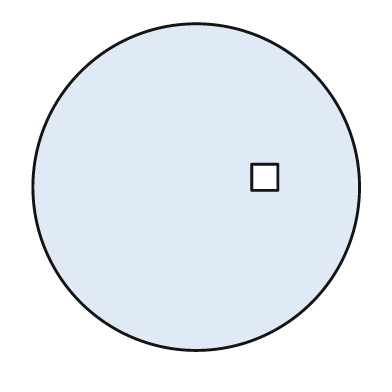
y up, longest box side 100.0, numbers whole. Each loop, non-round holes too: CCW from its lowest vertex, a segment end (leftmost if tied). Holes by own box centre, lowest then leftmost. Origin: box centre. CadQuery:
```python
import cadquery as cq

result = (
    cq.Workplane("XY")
    .moveTo(0.0, 0.0)
    .circle(50.0)
    .moveTo(17.0, -1.0)
    .lineTo(25.0, -1.0)
    .lineTo(25.0, 7.0)
    .lineTo(17.0, 7.0)
    .close()
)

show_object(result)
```